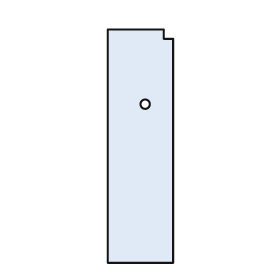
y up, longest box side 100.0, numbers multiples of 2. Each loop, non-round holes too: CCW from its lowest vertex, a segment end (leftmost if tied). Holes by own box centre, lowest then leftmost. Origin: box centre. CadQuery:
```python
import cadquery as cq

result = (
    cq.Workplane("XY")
    .moveTo(-14.0, -50.0)
    .lineTo(14.0, -50.0)
    .lineTo(14.0, 46.0)
    .lineTo(10.0, 46.0)
    .lineTo(10.0, 50.0)
    .lineTo(-14.0, 50.0)
    .close()
    .moveTo(2.0, 18.0)
    .circle(2.0)
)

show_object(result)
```